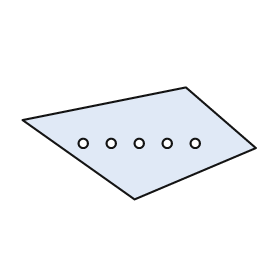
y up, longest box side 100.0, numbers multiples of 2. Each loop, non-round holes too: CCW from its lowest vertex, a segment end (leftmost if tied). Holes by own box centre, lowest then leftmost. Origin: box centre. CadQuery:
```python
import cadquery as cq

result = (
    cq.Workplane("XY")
    .moveTo(-2.0, -24.0)
    .lineTo(50.0, -2.0)
    .lineTo(20.0, 24.0)
    .lineTo(-50.0, 10.0)
    .close()
    .moveTo(-24.0, 0.0)
    .circle(2.0)
    .moveTo(-12.0, 0.0)
    .circle(2.0)
    .moveTo(0.0, 0.0)
    .circle(2.0)
    .moveTo(12.0, 0.0)
    .circle(2.0)
    .moveTo(24.0, 0.0)
    .circle(2.0)
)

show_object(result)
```